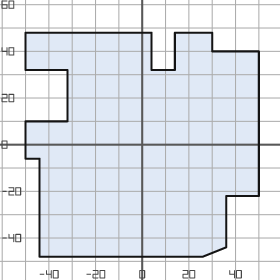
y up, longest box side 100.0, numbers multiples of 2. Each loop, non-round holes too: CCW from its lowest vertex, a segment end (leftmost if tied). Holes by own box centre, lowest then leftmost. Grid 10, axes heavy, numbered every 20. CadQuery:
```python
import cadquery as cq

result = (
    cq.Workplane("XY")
    .moveTo(-44.0, -48.0)
    .lineTo(26.0, -48.0)
    .lineTo(36.0, -44.0)
    .lineTo(36.0, -22.0)
    .lineTo(50.0, -22.0)
    .lineTo(50.0, 40.0)
    .lineTo(30.0, 40.0)
    .lineTo(30.0, 48.0)
    .lineTo(14.0, 48.0)
    .lineTo(14.0, 32.0)
    .lineTo(4.0, 32.0)
    .lineTo(4.0, 48.0)
    .lineTo(-50.0, 48.0)
    .lineTo(-50.0, 32.0)
    .lineTo(-32.0, 32.0)
    .lineTo(-32.0, 10.0)
    .lineTo(-50.0, 10.0)
    .lineTo(-50.0, -6.0)
    .lineTo(-44.0, -6.0)
    .close()
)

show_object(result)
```